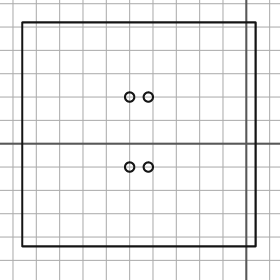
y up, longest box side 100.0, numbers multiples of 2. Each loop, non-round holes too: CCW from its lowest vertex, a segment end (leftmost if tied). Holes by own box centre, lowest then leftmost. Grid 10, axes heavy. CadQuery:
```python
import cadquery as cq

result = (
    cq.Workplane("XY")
    .moveTo(-96.0, -44.0)
    .lineTo(4.0, -44.0)
    .lineTo(4.0, 52.0)
    .lineTo(-96.0, 52.0)
    .close()
    .moveTo(-50.0, -10.0)
    .circle(2.0)
    .moveTo(-42.0, -10.0)
    .circle(2.0)
    .moveTo(-50.0, 20.0)
    .circle(2.0)
    .moveTo(-42.0, 20.0)
    .circle(2.0)
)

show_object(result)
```